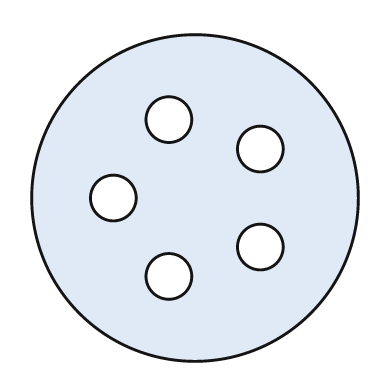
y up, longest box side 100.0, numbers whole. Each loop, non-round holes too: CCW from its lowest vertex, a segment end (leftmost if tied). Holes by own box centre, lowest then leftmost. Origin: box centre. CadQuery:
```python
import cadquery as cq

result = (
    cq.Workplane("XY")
    .moveTo(0.0, 0.0)
    .circle(50.0)
    .moveTo(-8.0, -24.0)
    .circle(7.0)
    .moveTo(20.0, -15.0)
    .circle(7.0)
    .moveTo(-25.0, 0.0)
    .circle(7.0)
    .moveTo(20.0, 15.0)
    .circle(7.0)
    .moveTo(-8.0, 24.0)
    .circle(7.0)
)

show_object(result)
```